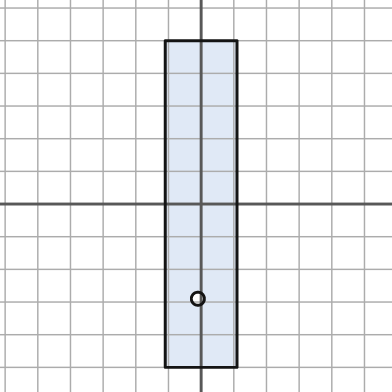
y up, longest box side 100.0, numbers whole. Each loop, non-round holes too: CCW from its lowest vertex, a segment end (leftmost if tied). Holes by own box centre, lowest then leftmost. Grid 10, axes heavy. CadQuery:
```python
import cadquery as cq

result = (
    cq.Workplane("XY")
    .moveTo(-11.0, -50.0)
    .lineTo(11.0, -50.0)
    .lineTo(11.0, 50.0)
    .lineTo(-11.0, 50.0)
    .close()
    .moveTo(-1.0, -29.0)
    .circle(2.0)
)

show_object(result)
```